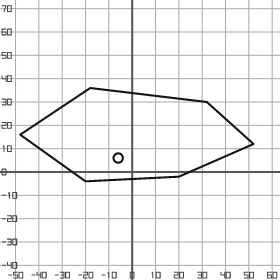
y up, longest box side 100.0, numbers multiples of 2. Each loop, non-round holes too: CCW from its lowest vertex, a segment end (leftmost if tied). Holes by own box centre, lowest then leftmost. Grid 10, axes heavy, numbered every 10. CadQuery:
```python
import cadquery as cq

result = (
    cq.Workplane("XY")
    .moveTo(-20.0, -4.0)
    .lineTo(20.0, -2.0)
    .lineTo(52.0, 12.0)
    .lineTo(32.0, 30.0)
    .lineTo(-18.0, 36.0)
    .lineTo(-48.0, 16.0)
    .close()
    .moveTo(-6.0, 6.0)
    .circle(2.0)
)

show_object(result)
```